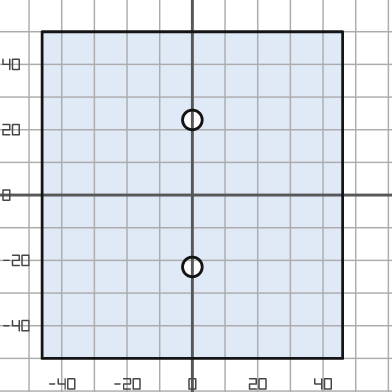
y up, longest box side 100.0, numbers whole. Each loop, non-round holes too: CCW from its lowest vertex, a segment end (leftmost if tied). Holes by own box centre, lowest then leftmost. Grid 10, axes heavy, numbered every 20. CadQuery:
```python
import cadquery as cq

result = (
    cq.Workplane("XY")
    .moveTo(-46.0, -50.0)
    .lineTo(46.0, -50.0)
    .lineTo(46.0, 50.0)
    .lineTo(-46.0, 50.0)
    .close()
    .moveTo(0.0, -22.0)
    .circle(3.0)
    .moveTo(0.0, 23.0)
    .circle(3.0)
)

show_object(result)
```